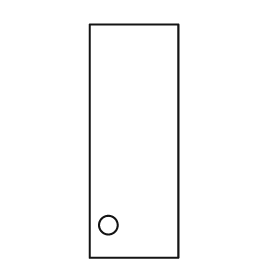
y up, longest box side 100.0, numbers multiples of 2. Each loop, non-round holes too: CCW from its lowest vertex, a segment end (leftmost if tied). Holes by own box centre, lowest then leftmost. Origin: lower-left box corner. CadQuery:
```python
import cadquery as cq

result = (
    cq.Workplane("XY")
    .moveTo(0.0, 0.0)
    .lineTo(38.0, 0.0)
    .lineTo(38.0, 100.0)
    .lineTo(0.0, 100.0)
    .close()
    .moveTo(8.0, 14.0)
    .circle(4.0)
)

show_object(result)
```